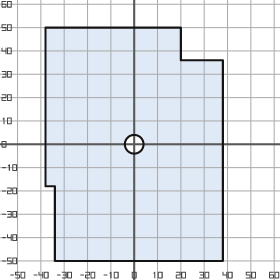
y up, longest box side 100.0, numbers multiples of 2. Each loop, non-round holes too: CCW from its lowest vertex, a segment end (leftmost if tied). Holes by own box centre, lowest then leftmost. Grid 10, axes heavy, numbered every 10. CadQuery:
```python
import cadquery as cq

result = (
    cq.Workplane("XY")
    .moveTo(-34.0, -50.0)
    .lineTo(38.0, -50.0)
    .lineTo(38.0, 36.0)
    .lineTo(20.0, 36.0)
    .lineTo(20.0, 50.0)
    .lineTo(-38.0, 50.0)
    .lineTo(-38.0, -18.0)
    .lineTo(-34.0, -18.0)
    .close()
    .moveTo(0.0, 0.0)
    .circle(4.0)
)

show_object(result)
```